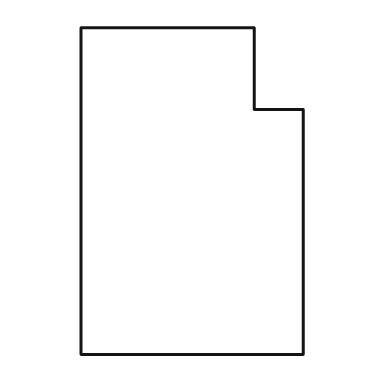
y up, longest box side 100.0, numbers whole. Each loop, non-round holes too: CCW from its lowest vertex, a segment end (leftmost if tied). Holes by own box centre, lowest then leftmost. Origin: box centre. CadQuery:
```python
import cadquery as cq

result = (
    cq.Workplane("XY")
    .moveTo(-34.0, -50.0)
    .lineTo(34.0, -50.0)
    .lineTo(34.0, 25.0)
    .lineTo(19.0, 25.0)
    .lineTo(19.0, 50.0)
    .lineTo(-34.0, 50.0)
    .close()
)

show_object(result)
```